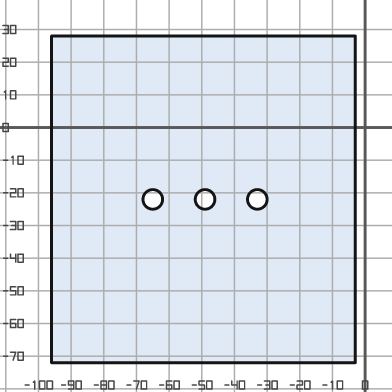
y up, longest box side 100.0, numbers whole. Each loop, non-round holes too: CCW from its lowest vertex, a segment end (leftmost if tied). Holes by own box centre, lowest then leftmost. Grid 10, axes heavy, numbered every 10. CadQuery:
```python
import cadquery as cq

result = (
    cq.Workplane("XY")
    .moveTo(-96.0, -72.0)
    .lineTo(-3.0, -72.0)
    .lineTo(-3.0, 28.0)
    .lineTo(-96.0, 28.0)
    .close()
    .moveTo(-65.0, -22.0)
    .circle(3.0)
    .moveTo(-49.0, -22.0)
    .circle(3.0)
    .moveTo(-33.0, -22.0)
    .circle(3.0)
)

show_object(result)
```